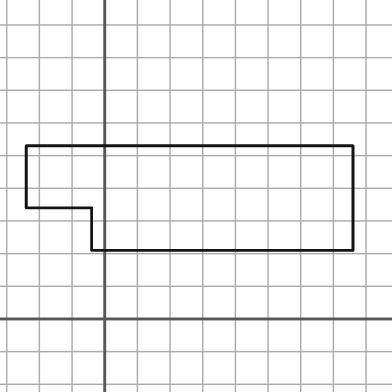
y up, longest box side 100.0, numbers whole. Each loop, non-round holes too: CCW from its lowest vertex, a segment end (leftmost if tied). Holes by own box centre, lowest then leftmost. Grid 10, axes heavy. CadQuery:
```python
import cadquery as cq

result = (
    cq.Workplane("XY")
    .moveTo(-4.0, 21.0)
    .lineTo(76.0, 21.0)
    .lineTo(76.0, 53.0)
    .lineTo(-24.0, 53.0)
    .lineTo(-24.0, 34.0)
    .lineTo(-4.0, 34.0)
    .close()
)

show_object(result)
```